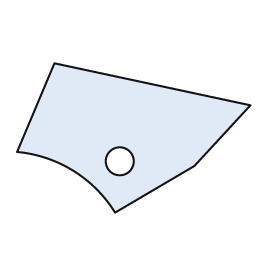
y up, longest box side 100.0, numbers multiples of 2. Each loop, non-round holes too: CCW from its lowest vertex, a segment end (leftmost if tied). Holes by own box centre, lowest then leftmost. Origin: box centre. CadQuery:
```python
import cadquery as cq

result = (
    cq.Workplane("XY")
    .moveTo(-8.0, -32.0)
    .lineTo(26.0, -12.0)
    .lineTo(50.0, 14.0)
    .lineTo(-34.0, 32.0)
    .lineTo(-50.0, -6.0)
    .threePointArc((-26.0, -14.0), (-8.0, -32.0))
    .close()
    .moveTo(-6.0, -10.0)
    .circle(6.0)
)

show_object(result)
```